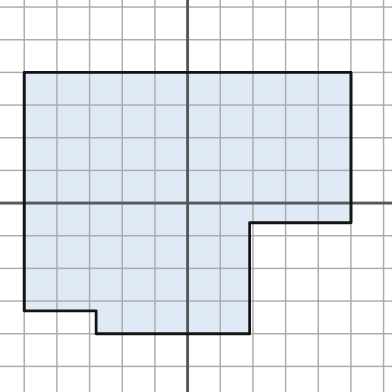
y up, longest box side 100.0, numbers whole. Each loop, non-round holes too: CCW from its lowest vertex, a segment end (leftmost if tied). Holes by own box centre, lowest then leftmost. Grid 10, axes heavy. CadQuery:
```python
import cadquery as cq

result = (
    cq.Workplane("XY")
    .moveTo(-28.0, -40.0)
    .lineTo(19.0, -40.0)
    .lineTo(19.0, -6.0)
    .lineTo(50.0, -6.0)
    .lineTo(50.0, 40.0)
    .lineTo(-50.0, 40.0)
    .lineTo(-50.0, -33.0)
    .lineTo(-28.0, -33.0)
    .close()
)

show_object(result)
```